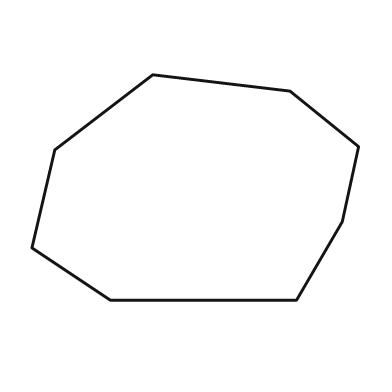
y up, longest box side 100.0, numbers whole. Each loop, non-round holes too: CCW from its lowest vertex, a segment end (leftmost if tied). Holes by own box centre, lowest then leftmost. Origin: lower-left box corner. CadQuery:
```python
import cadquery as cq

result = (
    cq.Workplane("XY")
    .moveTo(24.0, 0.0)
    .lineTo(81.0, 0.0)
    .lineTo(95.0, 24.0)
    .lineTo(100.0, 47.0)
    .lineTo(79.0, 64.0)
    .lineTo(37.0, 69.0)
    .lineTo(7.0, 46.0)
    .lineTo(0.0, 16.0)
    .close()
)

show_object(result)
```